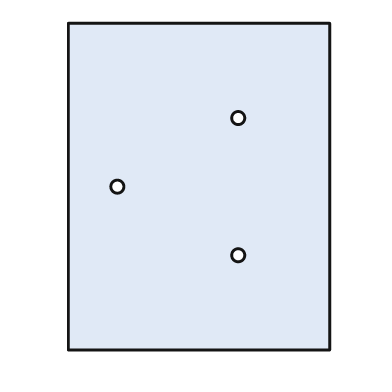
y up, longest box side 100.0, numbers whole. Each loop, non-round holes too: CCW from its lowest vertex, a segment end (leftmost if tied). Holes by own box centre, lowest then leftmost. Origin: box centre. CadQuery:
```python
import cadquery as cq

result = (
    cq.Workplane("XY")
    .moveTo(-40.0, -50.0)
    .lineTo(40.0, -50.0)
    .lineTo(40.0, 50.0)
    .lineTo(-40.0, 50.0)
    .close()
    .moveTo(12.0, -21.0)
    .circle(2.0)
    .moveTo(-25.0, 0.0)
    .circle(2.0)
    .moveTo(12.0, 21.0)
    .circle(2.0)
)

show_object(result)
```